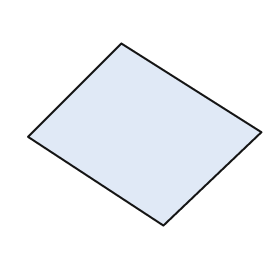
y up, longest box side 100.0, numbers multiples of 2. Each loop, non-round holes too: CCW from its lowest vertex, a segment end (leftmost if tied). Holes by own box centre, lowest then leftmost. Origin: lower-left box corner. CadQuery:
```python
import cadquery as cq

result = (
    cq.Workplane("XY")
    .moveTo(58.0, 0.0)
    .lineTo(100.0, 40.0)
    .lineTo(40.0, 78.0)
    .lineTo(0.0, 38.0)
    .close()
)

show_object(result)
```